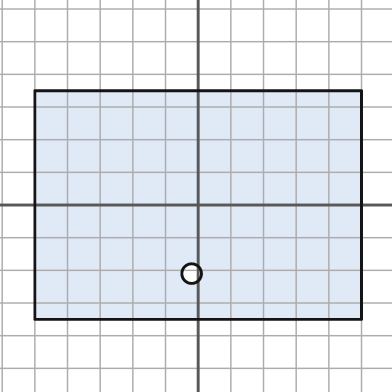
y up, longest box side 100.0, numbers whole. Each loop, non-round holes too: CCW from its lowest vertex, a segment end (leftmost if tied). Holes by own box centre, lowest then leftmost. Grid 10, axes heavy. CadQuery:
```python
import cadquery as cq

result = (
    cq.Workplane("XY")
    .moveTo(-50.0, -35.0)
    .lineTo(50.0, -35.0)
    .lineTo(50.0, 35.0)
    .lineTo(-50.0, 35.0)
    .close()
    .moveTo(-2.0, -21.0)
    .circle(3.0)
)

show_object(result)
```